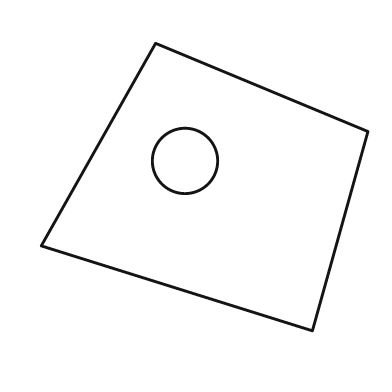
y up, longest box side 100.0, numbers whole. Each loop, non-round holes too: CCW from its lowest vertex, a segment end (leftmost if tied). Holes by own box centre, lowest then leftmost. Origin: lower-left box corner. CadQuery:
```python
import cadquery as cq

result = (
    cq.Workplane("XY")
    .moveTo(83.0, 0.0)
    .lineTo(100.0, 61.0)
    .lineTo(35.0, 88.0)
    .lineTo(0.0, 26.0)
    .close()
    .moveTo(44.0, 52.0)
    .circle(10.0)
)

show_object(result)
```